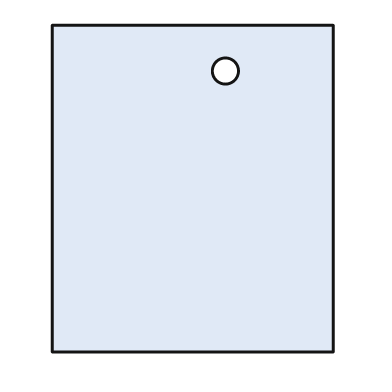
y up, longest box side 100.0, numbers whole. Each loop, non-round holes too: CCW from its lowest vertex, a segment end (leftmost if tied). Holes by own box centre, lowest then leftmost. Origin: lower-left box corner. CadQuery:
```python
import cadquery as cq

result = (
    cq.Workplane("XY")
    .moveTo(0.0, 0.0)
    .lineTo(86.0, 0.0)
    .lineTo(86.0, 100.0)
    .lineTo(0.0, 100.0)
    .close()
    .moveTo(53.0, 86.0)
    .circle(4.0)
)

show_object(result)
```